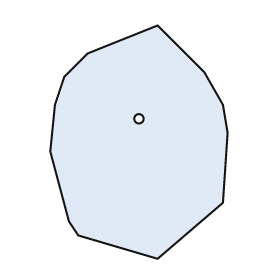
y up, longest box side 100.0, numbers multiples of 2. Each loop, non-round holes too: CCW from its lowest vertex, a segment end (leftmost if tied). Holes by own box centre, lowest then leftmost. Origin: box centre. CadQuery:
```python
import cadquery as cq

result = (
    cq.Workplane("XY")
    .moveTo(8.0, -50.0)
    .lineTo(36.0, -26.0)
    .lineTo(38.0, 4.0)
    .lineTo(36.0, 16.0)
    .lineTo(28.0, 30.0)
    .lineTo(8.0, 50.0)
    .lineTo(-22.0, 38.0)
    .lineTo(-32.0, 28.0)
    .lineTo(-36.0, 16.0)
    .lineTo(-38.0, -4.0)
    .lineTo(-30.0, -34.0)
    .lineTo(-26.0, -40.0)
    .close()
    .moveTo(0.0, 10.0)
    .circle(2.0)
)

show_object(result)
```